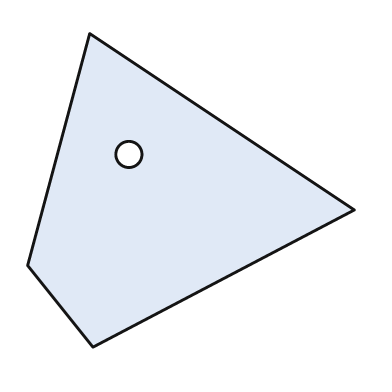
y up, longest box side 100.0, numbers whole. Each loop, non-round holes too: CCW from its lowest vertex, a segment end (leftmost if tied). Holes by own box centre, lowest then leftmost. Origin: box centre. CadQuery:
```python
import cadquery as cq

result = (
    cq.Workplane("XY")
    .moveTo(-30.0, -48.0)
    .lineTo(50.0, -6.0)
    .lineTo(-31.0, 48.0)
    .lineTo(-50.0, -23.0)
    .close()
    .moveTo(-19.0, 11.0)
    .circle(4.0)
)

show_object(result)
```